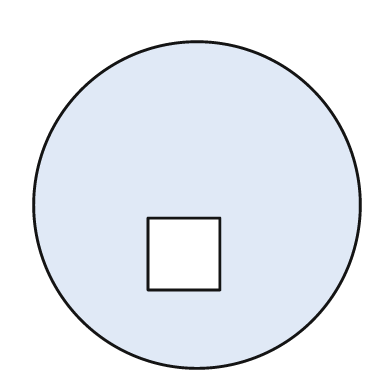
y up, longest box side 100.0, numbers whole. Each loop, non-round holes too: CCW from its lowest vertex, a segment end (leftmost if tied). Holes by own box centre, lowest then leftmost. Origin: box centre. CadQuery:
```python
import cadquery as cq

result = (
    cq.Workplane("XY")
    .moveTo(0.0, 0.0)
    .circle(50.0)
    .moveTo(-15.0, -26.0)
    .lineTo(7.0, -26.0)
    .lineTo(7.0, -4.0)
    .lineTo(-15.0, -4.0)
    .close()
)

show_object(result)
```